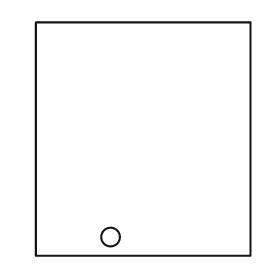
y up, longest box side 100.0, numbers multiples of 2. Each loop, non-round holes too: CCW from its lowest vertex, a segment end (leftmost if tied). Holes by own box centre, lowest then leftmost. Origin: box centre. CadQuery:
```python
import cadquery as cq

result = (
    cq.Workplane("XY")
    .moveTo(-46.0, -50.0)
    .lineTo(46.0, -50.0)
    .lineTo(46.0, 50.0)
    .lineTo(-46.0, 50.0)
    .close()
    .moveTo(-14.0, -42.0)
    .circle(4.0)
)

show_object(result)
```